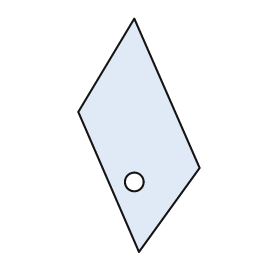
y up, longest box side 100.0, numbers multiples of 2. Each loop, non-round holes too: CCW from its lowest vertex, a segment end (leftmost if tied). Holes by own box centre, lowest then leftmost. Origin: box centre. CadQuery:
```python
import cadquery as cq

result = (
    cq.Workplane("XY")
    .moveTo(0.0, -50.0)
    .lineTo(26.0, -14.0)
    .lineTo(-2.0, 50.0)
    .lineTo(-26.0, 10.0)
    .close()
    .moveTo(-2.0, -20.0)
    .circle(4.0)
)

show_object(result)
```